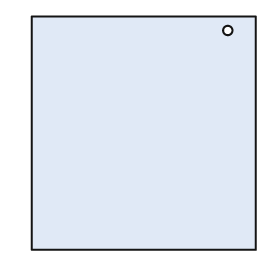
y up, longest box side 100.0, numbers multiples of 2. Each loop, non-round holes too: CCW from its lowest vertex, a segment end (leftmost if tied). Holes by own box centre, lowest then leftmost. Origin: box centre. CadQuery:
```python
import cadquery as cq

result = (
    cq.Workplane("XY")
    .moveTo(-48.0, -50.0)
    .lineTo(48.0, -50.0)
    .lineTo(48.0, 50.0)
    .lineTo(-48.0, 50.0)
    .close()
    .moveTo(36.0, 44.0)
    .circle(2.0)
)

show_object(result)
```